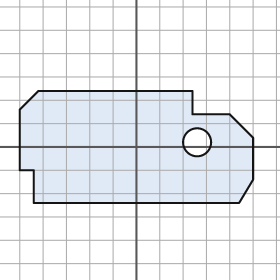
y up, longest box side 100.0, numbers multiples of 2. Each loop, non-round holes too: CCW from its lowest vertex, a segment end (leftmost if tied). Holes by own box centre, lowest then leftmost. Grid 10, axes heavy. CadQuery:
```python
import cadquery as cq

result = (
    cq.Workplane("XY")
    .moveTo(-44.0, -24.0)
    .lineTo(44.0, -24.0)
    .lineTo(50.0, -14.0)
    .lineTo(50.0, 4.0)
    .lineTo(40.0, 14.0)
    .lineTo(24.0, 14.0)
    .lineTo(24.0, 24.0)
    .lineTo(-42.0, 24.0)
    .lineTo(-50.0, 16.0)
    .lineTo(-50.0, -10.0)
    .lineTo(-44.0, -10.0)
    .close()
    .moveTo(26.0, 2.0)
    .circle(6.0)
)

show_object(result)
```